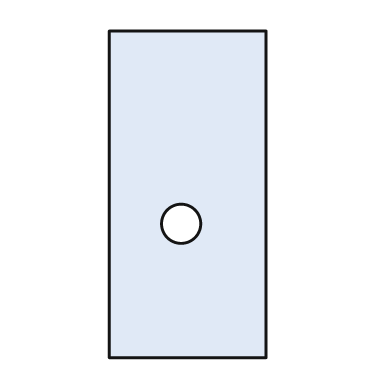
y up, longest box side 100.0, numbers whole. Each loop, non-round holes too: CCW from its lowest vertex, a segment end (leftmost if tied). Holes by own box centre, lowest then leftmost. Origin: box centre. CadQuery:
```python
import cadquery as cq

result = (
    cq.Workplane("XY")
    .moveTo(-24.0, -50.0)
    .lineTo(24.0, -50.0)
    .lineTo(24.0, 50.0)
    .lineTo(-24.0, 50.0)
    .close()
    .moveTo(-2.0, -9.0)
    .circle(6.0)
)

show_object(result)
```